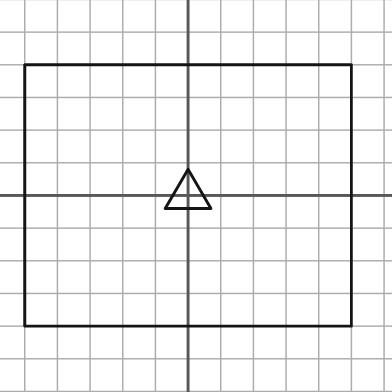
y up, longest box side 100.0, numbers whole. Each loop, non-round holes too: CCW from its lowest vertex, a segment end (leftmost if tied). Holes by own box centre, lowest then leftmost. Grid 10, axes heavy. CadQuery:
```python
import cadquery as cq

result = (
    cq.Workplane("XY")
    .moveTo(-50.0, -40.0)
    .lineTo(50.0, -40.0)
    .lineTo(50.0, 40.0)
    .lineTo(-50.0, 40.0)
    .close()
    .moveTo(-7.0, -4.0)
    .lineTo(7.0, -4.0)
    .lineTo(0.0, 8.0)
    .close()
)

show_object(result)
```